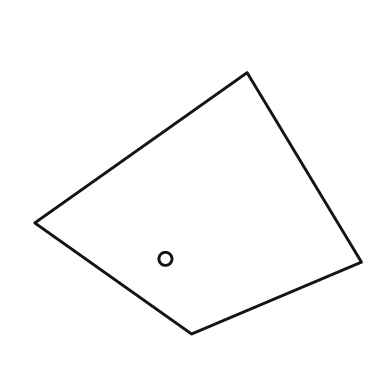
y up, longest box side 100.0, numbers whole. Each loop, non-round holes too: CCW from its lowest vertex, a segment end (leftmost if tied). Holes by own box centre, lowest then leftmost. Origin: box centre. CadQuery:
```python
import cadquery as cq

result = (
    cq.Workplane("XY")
    .moveTo(-2.0, -40.0)
    .lineTo(50.0, -18.0)
    .lineTo(15.0, 40.0)
    .lineTo(-50.0, -6.0)
    .close()
    .moveTo(-10.0, -17.0)
    .circle(2.0)
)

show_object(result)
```